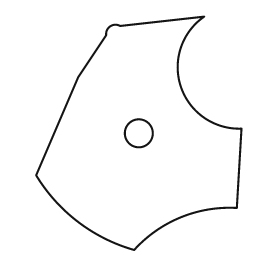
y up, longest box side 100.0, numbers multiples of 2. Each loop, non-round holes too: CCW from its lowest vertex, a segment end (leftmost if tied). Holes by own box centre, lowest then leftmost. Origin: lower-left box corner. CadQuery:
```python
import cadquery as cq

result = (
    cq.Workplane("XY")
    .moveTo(42.0, 0.0)
    .threePointArc((62.0, 14.0), (86.0, 18.0))
    .lineTo(88.0, 52.0)
    .threePointArc((62.0, 70.0), (72.0, 100.0))
    .lineTo(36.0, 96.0)
    .threePointArc((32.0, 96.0), (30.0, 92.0))
    .lineTo(18.0, 74.0)
    .lineTo(0.0, 32.0)
    .threePointArc((18.0, 12.0), (42.0, 0.0))
    .close()
    .moveTo(44.0, 50.0)
    .circle(6.0)
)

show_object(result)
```